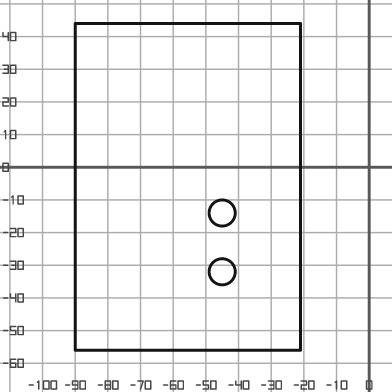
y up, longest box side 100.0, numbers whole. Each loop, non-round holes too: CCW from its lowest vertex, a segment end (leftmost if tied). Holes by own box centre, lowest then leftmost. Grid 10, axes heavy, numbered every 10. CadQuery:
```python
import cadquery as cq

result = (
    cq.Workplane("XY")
    .moveTo(-90.0, -56.0)
    .lineTo(-21.0, -56.0)
    .lineTo(-21.0, 44.0)
    .lineTo(-90.0, 44.0)
    .close()
    .moveTo(-45.0, -32.0)
    .circle(4.0)
    .moveTo(-45.0, -14.0)
    .circle(4.0)
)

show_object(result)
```